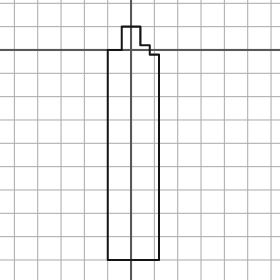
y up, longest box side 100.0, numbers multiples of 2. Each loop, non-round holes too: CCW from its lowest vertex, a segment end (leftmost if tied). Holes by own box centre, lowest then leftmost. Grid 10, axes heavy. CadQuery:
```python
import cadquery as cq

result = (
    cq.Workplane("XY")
    .moveTo(-10.0, -90.0)
    .lineTo(12.0, -90.0)
    .lineTo(12.0, -2.0)
    .lineTo(8.0, -2.0)
    .lineTo(8.0, 2.0)
    .lineTo(4.0, 2.0)
    .lineTo(4.0, 10.0)
    .lineTo(-4.0, 10.0)
    .lineTo(-4.0, 0.0)
    .lineTo(-10.0, 0.0)
    .close()
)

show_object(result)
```